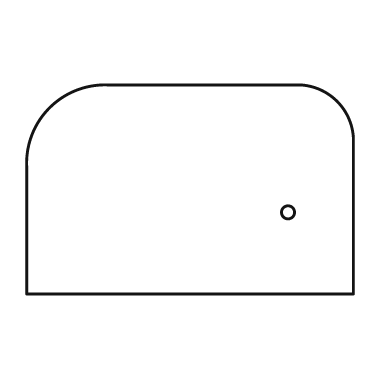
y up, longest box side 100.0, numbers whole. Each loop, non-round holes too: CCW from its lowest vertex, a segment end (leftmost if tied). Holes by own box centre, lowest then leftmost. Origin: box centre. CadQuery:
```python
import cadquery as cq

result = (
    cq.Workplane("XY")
    .moveTo(-50.0, -32.0)
    .lineTo(50.0, -32.0)
    .lineTo(50.0, 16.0)
    .threePointArc((45.0, 27.0), (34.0, 32.0))
    .lineTo(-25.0, 32.0)
    .threePointArc((-43.0, 25.0), (-50.0, 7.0))
    .close()
    .moveTo(30.0, -7.0)
    .circle(2.0)
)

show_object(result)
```